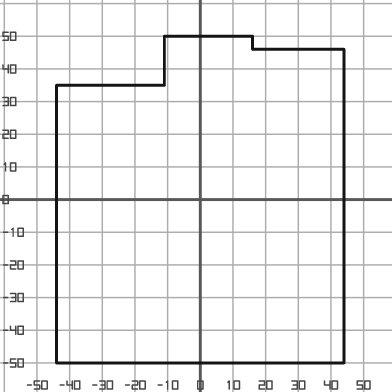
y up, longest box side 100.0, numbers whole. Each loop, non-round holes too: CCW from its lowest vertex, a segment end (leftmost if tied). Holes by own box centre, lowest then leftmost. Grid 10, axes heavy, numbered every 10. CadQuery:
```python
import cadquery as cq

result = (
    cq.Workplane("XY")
    .moveTo(-44.0, -50.0)
    .lineTo(44.0, -50.0)
    .lineTo(44.0, 46.0)
    .lineTo(16.0, 46.0)
    .lineTo(16.0, 50.0)
    .lineTo(-11.0, 50.0)
    .lineTo(-11.0, 35.0)
    .lineTo(-44.0, 35.0)
    .close()
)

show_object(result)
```